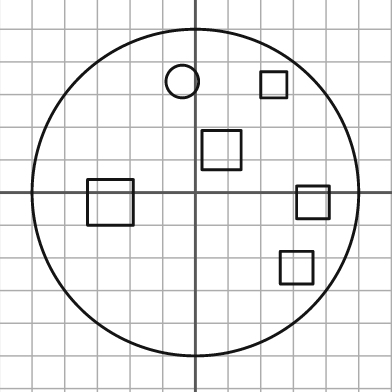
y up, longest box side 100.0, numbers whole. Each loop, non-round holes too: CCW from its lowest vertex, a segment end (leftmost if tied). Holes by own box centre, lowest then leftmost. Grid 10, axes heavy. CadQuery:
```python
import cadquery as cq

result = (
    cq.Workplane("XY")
    .moveTo(0.0, 0.0)
    .circle(50.0)
    .moveTo(26.0, -28.0)
    .lineTo(36.0, -28.0)
    .lineTo(36.0, -18.0)
    .lineTo(26.0, -18.0)
    .close()
    .moveTo(-33.0, -10.0)
    .lineTo(-19.0, -10.0)
    .lineTo(-19.0, 4.0)
    .lineTo(-33.0, 4.0)
    .close()
    .moveTo(31.0, -8.0)
    .lineTo(41.0, -8.0)
    .lineTo(41.0, 2.0)
    .lineTo(31.0, 2.0)
    .close()
    .moveTo(2.0, 7.0)
    .lineTo(14.0, 7.0)
    .lineTo(14.0, 19.0)
    .lineTo(2.0, 19.0)
    .close()
    .moveTo(20.0, 29.0)
    .lineTo(28.0, 29.0)
    .lineTo(28.0, 37.0)
    .lineTo(20.0, 37.0)
    .close()
    .moveTo(-4.0, 34.0)
    .circle(5.0)
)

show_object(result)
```